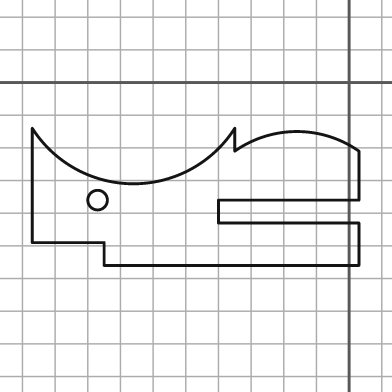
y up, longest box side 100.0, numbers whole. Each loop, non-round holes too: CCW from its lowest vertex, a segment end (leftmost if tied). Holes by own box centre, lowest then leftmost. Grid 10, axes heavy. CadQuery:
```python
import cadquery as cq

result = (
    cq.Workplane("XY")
    .moveTo(-75.0, -56.0)
    .lineTo(3.0, -56.0)
    .lineTo(3.0, -43.0)
    .lineTo(-40.0, -43.0)
    .lineTo(-40.0, -36.0)
    .lineTo(3.0, -36.0)
    .lineTo(3.0, -21.0)
    .threePointArc((-16.0, -15.0), (-35.0, -21.0))
    .lineTo(-35.0, -14.0)
    .threePointArc((-66.0, -31.0), (-97.0, -14.0))
    .lineTo(-97.0, -49.0)
    .lineTo(-75.0, -49.0)
    .close()
    .moveTo(-77.0, -36.0)
    .circle(3.0)
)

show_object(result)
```